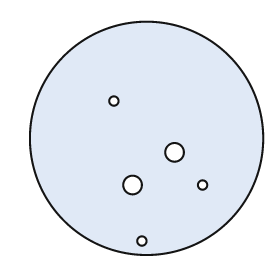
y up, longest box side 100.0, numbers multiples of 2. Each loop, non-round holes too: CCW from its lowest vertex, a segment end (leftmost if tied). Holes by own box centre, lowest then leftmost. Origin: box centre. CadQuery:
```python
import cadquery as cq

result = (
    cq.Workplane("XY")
    .moveTo(0.0, 0.0)
    .circle(50.0)
    .moveTo(-2.0, -44.0)
    .circle(2.0)
    .moveTo(-6.0, -20.0)
    .circle(4.0)
    .moveTo(24.0, -20.0)
    .circle(2.0)
    .moveTo(12.0, -6.0)
    .circle(4.0)
    .moveTo(-14.0, 16.0)
    .circle(2.0)
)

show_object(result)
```